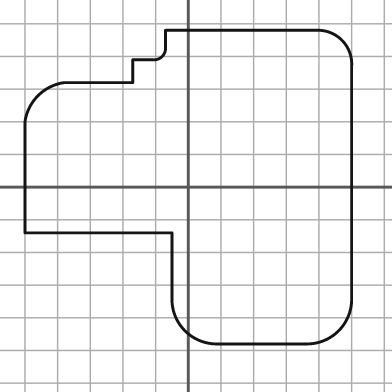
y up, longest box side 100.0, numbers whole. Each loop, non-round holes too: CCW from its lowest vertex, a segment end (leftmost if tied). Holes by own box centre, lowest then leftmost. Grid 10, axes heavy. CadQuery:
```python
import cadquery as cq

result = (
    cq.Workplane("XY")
    .moveTo(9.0, -48.0)
    .lineTo(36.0, -48.0)
    .threePointArc((46.0, -44.0), (50.0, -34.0))
    .lineTo(50.0, 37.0)
    .threePointArc((47.0, 45.0), (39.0, 48.0))
    .lineTo(-7.0, 48.0)
    .lineTo(-7.0, 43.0)
    .threePointArc((-8.0, 40.0), (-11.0, 39.0))
    .lineTo(-17.0, 39.0)
    .lineTo(-17.0, 32.0)
    .lineTo(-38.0, 32.0)
    .threePointArc((-46.0, 28.0), (-50.0, 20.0))
    .lineTo(-50.0, -14.0)
    .lineTo(-5.0, -14.0)
    .lineTo(-5.0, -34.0)
    .threePointArc((-1.0, -44.0), (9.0, -48.0))
    .close()
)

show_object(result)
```